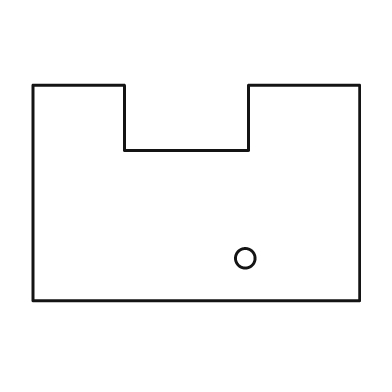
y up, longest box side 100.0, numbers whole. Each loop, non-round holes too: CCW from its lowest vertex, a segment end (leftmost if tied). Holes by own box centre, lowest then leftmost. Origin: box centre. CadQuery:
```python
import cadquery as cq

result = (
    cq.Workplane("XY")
    .moveTo(-50.0, -33.0)
    .lineTo(50.0, -33.0)
    .lineTo(50.0, 33.0)
    .lineTo(16.0, 33.0)
    .lineTo(16.0, 13.0)
    .lineTo(-22.0, 13.0)
    .lineTo(-22.0, 33.0)
    .lineTo(-50.0, 33.0)
    .close()
    .moveTo(15.0, -20.0)
    .circle(3.0)
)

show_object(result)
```